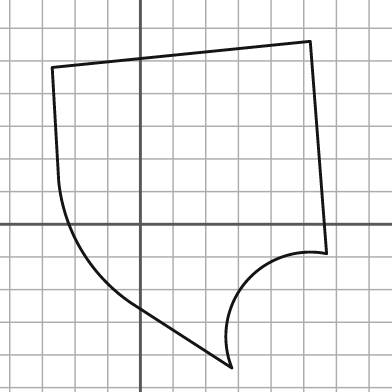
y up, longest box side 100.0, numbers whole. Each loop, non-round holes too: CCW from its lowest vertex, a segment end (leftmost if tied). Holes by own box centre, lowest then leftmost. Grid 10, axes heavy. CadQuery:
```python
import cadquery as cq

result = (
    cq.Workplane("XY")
    .moveTo(28.0, -44.0)
    .threePointArc((32.0, -18.0), (57.0, -9.0))
    .lineTo(52.0, 56.0)
    .lineTo(-27.0, 48.0)
    .lineTo(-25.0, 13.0)
    .threePointArc((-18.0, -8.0), (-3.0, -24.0))
    .close()
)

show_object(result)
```